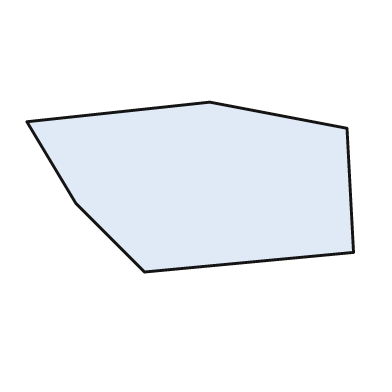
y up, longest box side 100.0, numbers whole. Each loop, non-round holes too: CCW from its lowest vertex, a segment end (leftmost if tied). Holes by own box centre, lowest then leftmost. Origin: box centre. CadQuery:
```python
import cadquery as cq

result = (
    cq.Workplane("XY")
    .moveTo(-14.0, -26.0)
    .lineTo(50.0, -20.0)
    .lineTo(48.0, 18.0)
    .lineTo(6.0, 26.0)
    .lineTo(-50.0, 20.0)
    .lineTo(-35.0, -5.0)
    .close()
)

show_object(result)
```